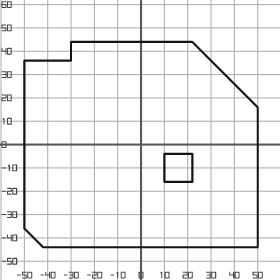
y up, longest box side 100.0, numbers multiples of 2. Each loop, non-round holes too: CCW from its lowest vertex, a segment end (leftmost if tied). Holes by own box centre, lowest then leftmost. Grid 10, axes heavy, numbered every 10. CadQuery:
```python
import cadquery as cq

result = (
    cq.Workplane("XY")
    .moveTo(-42.0, -44.0)
    .lineTo(50.0, -44.0)
    .lineTo(50.0, 16.0)
    .lineTo(22.0, 44.0)
    .lineTo(-30.0, 44.0)
    .lineTo(-30.0, 36.0)
    .lineTo(-50.0, 36.0)
    .lineTo(-50.0, -36.0)
    .close()
    .moveTo(10.0, -16.0)
    .lineTo(22.0, -16.0)
    .lineTo(22.0, -4.0)
    .lineTo(10.0, -4.0)
    .close()
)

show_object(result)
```